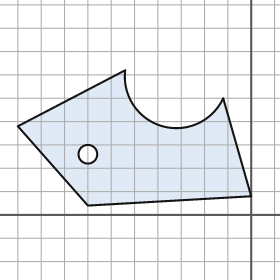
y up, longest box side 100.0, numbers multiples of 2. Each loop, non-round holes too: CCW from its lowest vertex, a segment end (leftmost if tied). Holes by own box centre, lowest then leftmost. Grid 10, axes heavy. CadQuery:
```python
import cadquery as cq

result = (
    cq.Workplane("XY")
    .moveTo(-70.0, 4.0)
    .lineTo(0.0, 8.0)
    .lineTo(-12.0, 50.0)
    .threePointArc((-38.0, 38.0), (-54.0, 62.0))
    .lineTo(-100.0, 38.0)
    .close()
    .moveTo(-70.0, 26.0)
    .circle(4.0)
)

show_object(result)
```